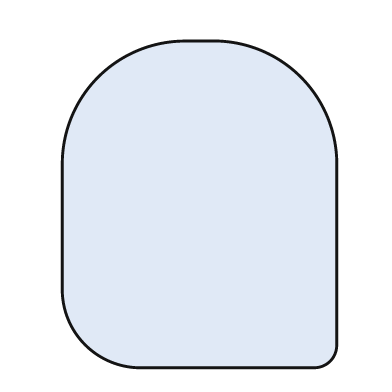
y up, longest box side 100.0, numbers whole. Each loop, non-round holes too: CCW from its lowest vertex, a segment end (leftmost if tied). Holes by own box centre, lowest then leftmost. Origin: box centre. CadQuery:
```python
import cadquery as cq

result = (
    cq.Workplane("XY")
    .moveTo(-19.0, -50.0)
    .lineTo(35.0, -50.0)
    .threePointArc((40.0, -48.0), (42.0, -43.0))
    .lineTo(42.0, 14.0)
    .threePointArc((31.0, 39.0), (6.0, 50.0))
    .lineTo(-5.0, 50.0)
    .threePointArc((-31.0, 39.0), (-42.0, 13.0))
    .lineTo(-42.0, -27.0)
    .threePointArc((-35.0, -43.0), (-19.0, -50.0))
    .close()
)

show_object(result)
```